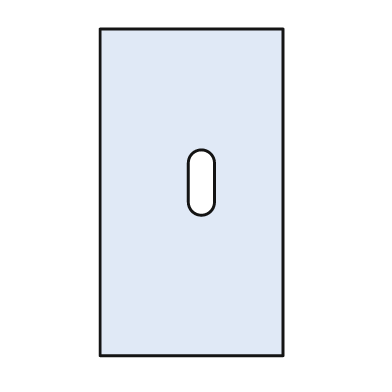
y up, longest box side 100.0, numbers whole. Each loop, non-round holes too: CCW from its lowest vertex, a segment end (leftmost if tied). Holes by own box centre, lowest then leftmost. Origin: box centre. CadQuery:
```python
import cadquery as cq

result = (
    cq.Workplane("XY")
    .moveTo(-28.0, -50.0)
    .lineTo(28.0, -50.0)
    .lineTo(28.0, 50.0)
    .lineTo(-28.0, 50.0)
    .close()
    .moveTo(-1.0, -3.0)
    .threePointArc((3.0, -7.0), (7.0, -3.0))
    .lineTo(7.0, 9.0)
    .threePointArc((3.0, 13.0), (-1.0, 9.0))
    .close()
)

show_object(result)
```